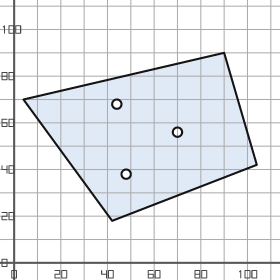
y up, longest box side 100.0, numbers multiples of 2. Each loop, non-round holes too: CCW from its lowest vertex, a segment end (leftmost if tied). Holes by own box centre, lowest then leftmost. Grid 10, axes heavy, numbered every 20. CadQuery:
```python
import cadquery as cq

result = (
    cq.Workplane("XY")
    .moveTo(42.0, 18.0)
    .lineTo(104.0, 42.0)
    .lineTo(90.0, 90.0)
    .lineTo(4.0, 70.0)
    .close()
    .moveTo(48.0, 38.0)
    .circle(2.0)
    .moveTo(70.0, 56.0)
    .circle(2.0)
    .moveTo(44.0, 68.0)
    .circle(2.0)
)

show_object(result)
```